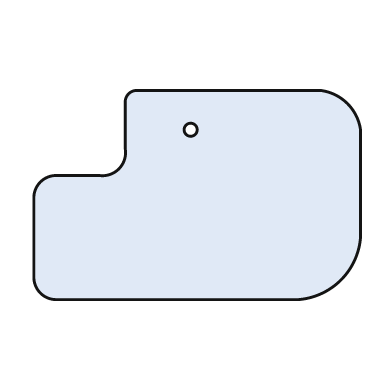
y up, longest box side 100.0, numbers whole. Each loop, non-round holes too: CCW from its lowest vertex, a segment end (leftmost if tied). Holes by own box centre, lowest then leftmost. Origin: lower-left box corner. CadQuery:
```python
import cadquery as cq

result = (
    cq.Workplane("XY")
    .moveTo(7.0, 0.0)
    .lineTo(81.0, 0.0)
    .threePointArc((94.0, 6.0), (100.0, 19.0))
    .lineTo(100.0, 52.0)
    .threePointArc((96.0, 60.0), (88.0, 64.0))
    .lineTo(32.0, 64.0)
    .threePointArc((29.0, 63.0), (28.0, 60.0))
    .lineTo(28.0, 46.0)
    .threePointArc((26.0, 40.0), (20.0, 38.0))
    .lineTo(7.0, 38.0)
    .threePointArc((2.0, 36.0), (0.0, 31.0))
    .lineTo(0.0, 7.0)
    .threePointArc((2.0, 2.0), (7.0, 0.0))
    .close()
    .moveTo(48.0, 52.0)
    .circle(2.0)
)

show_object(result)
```